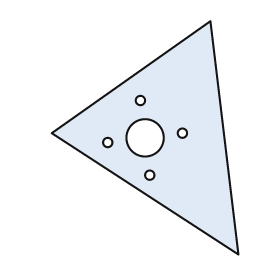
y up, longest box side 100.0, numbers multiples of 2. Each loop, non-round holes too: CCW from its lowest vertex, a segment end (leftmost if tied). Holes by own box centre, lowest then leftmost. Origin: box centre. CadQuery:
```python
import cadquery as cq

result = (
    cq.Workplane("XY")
    .moveTo(40.0, -50.0)
    .lineTo(28.0, 50.0)
    .lineTo(-40.0, 2.0)
    .close()
    .moveTo(2.0, -16.0)
    .circle(2.0)
    .moveTo(-16.0, -2.0)
    .circle(2.0)
    .moveTo(0.0, 0.0)
    .circle(8.0)
    .moveTo(16.0, 2.0)
    .circle(2.0)
    .moveTo(-2.0, 16.0)
    .circle(2.0)
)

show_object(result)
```